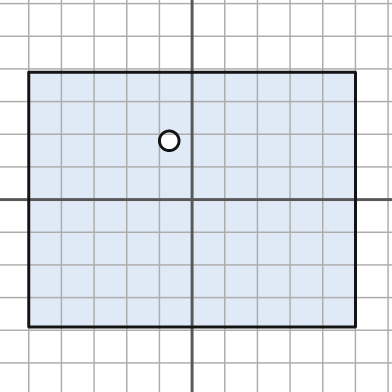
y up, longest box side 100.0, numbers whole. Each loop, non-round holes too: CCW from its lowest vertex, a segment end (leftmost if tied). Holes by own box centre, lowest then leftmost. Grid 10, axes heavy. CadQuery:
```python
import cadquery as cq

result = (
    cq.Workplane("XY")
    .moveTo(-50.0, -39.0)
    .lineTo(50.0, -39.0)
    .lineTo(50.0, 39.0)
    .lineTo(-50.0, 39.0)
    .close()
    .moveTo(-7.0, 18.0)
    .circle(3.0)
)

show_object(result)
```